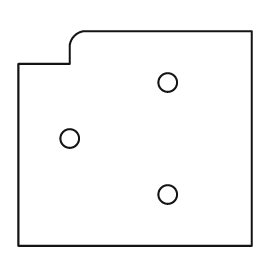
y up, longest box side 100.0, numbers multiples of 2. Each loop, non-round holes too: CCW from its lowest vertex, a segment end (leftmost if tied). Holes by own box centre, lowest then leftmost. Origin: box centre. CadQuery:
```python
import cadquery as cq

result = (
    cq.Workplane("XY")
    .moveTo(-50.0, -46.0)
    .lineTo(50.0, -46.0)
    .lineTo(50.0, 46.0)
    .lineTo(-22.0, 46.0)
    .threePointArc((-26.0, 44.0), (-28.0, 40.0))
    .lineTo(-28.0, 32.0)
    .lineTo(-50.0, 32.0)
    .close()
    .moveTo(14.0, -24.0)
    .circle(4.0)
    .moveTo(-28.0, 0.0)
    .circle(4.0)
    .moveTo(14.0, 24.0)
    .circle(4.0)
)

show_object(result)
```